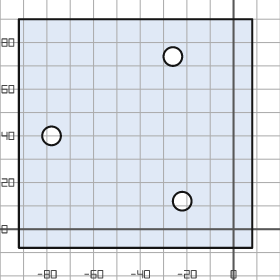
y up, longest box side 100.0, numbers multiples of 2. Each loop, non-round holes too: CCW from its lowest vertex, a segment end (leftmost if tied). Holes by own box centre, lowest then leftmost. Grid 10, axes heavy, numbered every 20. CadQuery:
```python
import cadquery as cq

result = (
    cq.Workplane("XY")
    .moveTo(-92.0, -8.0)
    .lineTo(8.0, -8.0)
    .lineTo(8.0, 90.0)
    .lineTo(-92.0, 90.0)
    .close()
    .moveTo(-22.0, 12.0)
    .circle(4.0)
    .moveTo(-78.0, 40.0)
    .circle(4.0)
    .moveTo(-26.0, 74.0)
    .circle(4.0)
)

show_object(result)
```